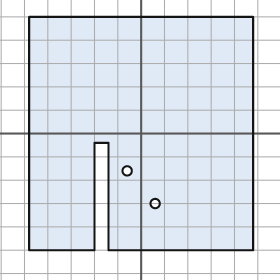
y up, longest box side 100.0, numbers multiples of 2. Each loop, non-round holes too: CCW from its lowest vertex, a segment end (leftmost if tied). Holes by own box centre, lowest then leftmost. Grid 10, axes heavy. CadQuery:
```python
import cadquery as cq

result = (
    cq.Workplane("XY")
    .moveTo(-48.0, -50.0)
    .lineTo(-20.0, -50.0)
    .lineTo(-20.0, -4.0)
    .lineTo(-14.0, -4.0)
    .lineTo(-14.0, -50.0)
    .lineTo(48.0, -50.0)
    .lineTo(48.0, 50.0)
    .lineTo(-48.0, 50.0)
    .close()
    .moveTo(6.0, -30.0)
    .circle(2.0)
    .moveTo(-6.0, -16.0)
    .circle(2.0)
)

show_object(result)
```